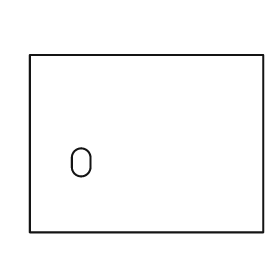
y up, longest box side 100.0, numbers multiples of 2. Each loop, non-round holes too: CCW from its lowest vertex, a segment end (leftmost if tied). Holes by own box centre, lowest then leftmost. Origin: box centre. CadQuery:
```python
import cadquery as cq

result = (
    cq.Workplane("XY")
    .moveTo(-50.0, -38.0)
    .lineTo(50.0, -38.0)
    .lineTo(50.0, 38.0)
    .lineTo(-50.0, 38.0)
    .close()
    .moveTo(-32.0, -10.0)
    .threePointArc((-28.0, -14.0), (-24.0, -10.0))
    .lineTo(-24.0, -6.0)
    .threePointArc((-28.0, -2.0), (-32.0, -6.0))
    .close()
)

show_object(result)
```